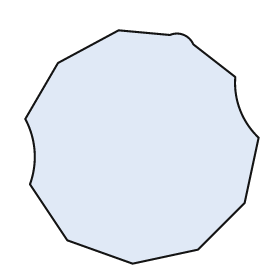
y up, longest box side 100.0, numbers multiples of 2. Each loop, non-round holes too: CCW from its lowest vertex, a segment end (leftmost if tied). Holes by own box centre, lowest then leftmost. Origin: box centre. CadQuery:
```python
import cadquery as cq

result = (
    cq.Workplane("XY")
    .moveTo(-4.0, -50.0)
    .lineTo(24.0, -44.0)
    .lineTo(44.0, -24.0)
    .lineTo(50.0, 4.0)
    .threePointArc((42.0, 16.0), (40.0, 30.0))
    .lineTo(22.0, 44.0)
    .threePointArc((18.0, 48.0), (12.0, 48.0))
    .lineTo(-10.0, 50.0)
    .lineTo(-36.0, 36.0)
    .lineTo(-50.0, 12.0)
    .threePointArc((-46.0, -2.0), (-48.0, -16.0))
    .lineTo(-32.0, -40.0)
    .close()
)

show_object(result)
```